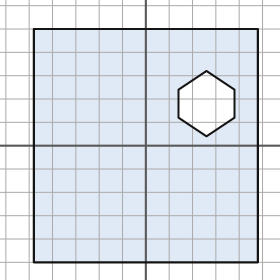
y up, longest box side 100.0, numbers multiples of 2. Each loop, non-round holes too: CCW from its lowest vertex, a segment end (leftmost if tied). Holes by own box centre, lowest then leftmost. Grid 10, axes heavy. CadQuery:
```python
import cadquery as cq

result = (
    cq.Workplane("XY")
    .moveTo(-48.0, -50.0)
    .lineTo(48.0, -50.0)
    .lineTo(48.0, 50.0)
    .lineTo(-48.0, 50.0)
    .close()
    .moveTo(26.0, 4.0)
    .lineTo(38.0, 12.0)
    .lineTo(38.0, 24.0)
    .lineTo(26.0, 32.0)
    .lineTo(14.0, 24.0)
    .lineTo(14.0, 12.0)
    .close()
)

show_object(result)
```